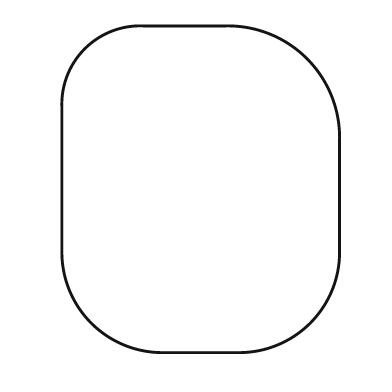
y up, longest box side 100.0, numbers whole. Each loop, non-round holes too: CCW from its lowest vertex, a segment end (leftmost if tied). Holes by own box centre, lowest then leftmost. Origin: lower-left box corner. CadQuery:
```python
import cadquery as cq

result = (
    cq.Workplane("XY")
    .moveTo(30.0, 0.0)
    .lineTo(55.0, 0.0)
    .threePointArc((76.0, 9.0), (85.0, 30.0))
    .lineTo(85.0, 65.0)
    .threePointArc((75.0, 90.0), (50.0, 100.0))
    .lineTo(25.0, 100.0)
    .threePointArc((7.0, 93.0), (0.0, 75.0))
    .lineTo(0.0, 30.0)
    .threePointArc((9.0, 9.0), (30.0, 0.0))
    .close()
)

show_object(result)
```